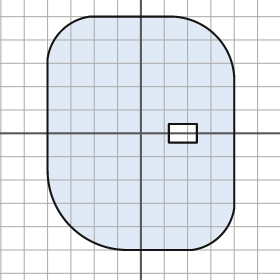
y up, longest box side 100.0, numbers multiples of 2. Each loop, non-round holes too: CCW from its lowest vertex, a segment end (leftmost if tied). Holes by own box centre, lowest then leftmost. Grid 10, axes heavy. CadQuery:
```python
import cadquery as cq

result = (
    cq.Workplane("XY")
    .moveTo(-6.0, -50.0)
    .lineTo(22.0, -50.0)
    .threePointArc((34.0, -44.0), (40.0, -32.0))
    .lineTo(40.0, 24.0)
    .threePointArc((32.0, 42.0), (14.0, 50.0))
    .lineTo(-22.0, 50.0)
    .threePointArc((-34.0, 44.0), (-40.0, 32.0))
    .lineTo(-40.0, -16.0)
    .threePointArc((-30.0, -40.0), (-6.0, -50.0))
    .close()
    .moveTo(12.0, -4.0)
    .lineTo(24.0, -4.0)
    .lineTo(24.0, 4.0)
    .lineTo(12.0, 4.0)
    .close()
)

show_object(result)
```